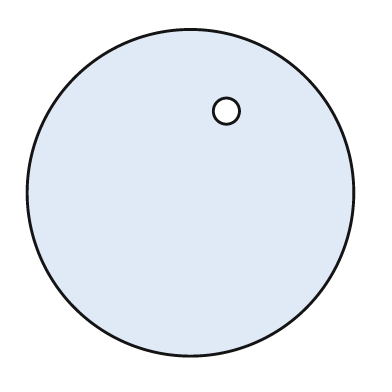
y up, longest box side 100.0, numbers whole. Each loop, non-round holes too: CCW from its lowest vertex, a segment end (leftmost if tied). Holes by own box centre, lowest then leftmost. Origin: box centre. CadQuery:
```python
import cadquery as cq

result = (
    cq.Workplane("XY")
    .moveTo(0.0, 0.0)
    .circle(50.0)
    .moveTo(11.0, 25.0)
    .circle(4.0)
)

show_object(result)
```